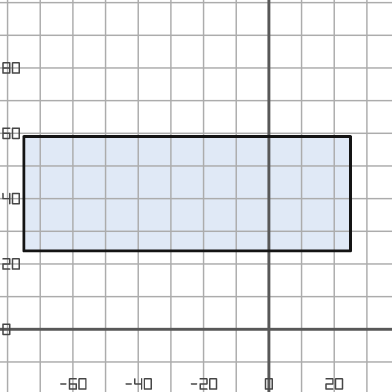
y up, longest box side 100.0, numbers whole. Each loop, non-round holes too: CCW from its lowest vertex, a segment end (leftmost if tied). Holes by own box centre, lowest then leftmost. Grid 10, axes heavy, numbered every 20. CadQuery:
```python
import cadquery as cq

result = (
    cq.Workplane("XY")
    .moveTo(-75.0, 24.0)
    .lineTo(25.0, 24.0)
    .lineTo(25.0, 59.0)
    .lineTo(-75.0, 59.0)
    .close()
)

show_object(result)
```